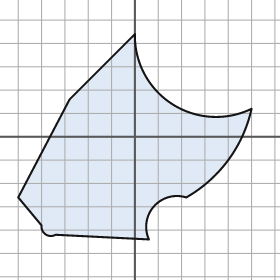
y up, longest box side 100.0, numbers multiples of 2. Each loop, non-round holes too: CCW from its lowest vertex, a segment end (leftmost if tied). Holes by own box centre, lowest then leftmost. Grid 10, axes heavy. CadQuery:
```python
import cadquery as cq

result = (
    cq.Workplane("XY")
    .moveTo(6.0, -44.0)
    .threePointArc((8.0, -30.0), (22.0, -26.0))
    .threePointArc((40.0, -10.0), (50.0, 12.0))
    .threePointArc((16.0, 14.0), (0.0, 44.0))
    .lineTo(-28.0, 16.0)
    .lineTo(-50.0, -26.0)
    .lineTo(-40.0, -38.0)
    .threePointArc((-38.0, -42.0), (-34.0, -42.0))
    .close()
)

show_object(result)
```